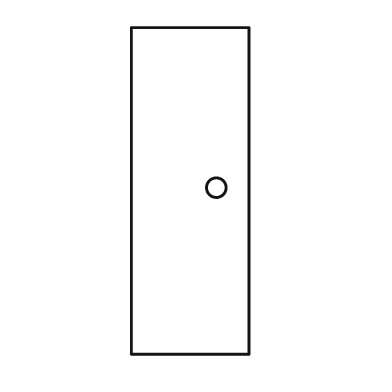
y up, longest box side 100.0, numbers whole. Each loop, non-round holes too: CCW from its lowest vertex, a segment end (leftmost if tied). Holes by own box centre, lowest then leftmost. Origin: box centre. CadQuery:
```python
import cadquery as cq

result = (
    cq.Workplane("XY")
    .moveTo(-18.0, -50.0)
    .lineTo(18.0, -50.0)
    .lineTo(18.0, 50.0)
    .lineTo(-18.0, 50.0)
    .close()
    .moveTo(8.0, 1.0)
    .circle(3.0)
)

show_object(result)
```